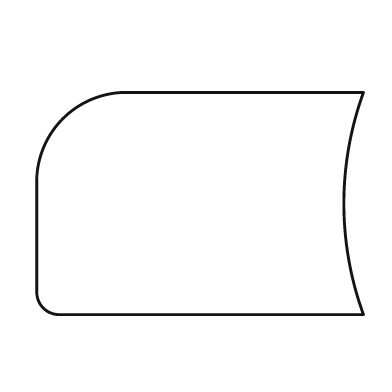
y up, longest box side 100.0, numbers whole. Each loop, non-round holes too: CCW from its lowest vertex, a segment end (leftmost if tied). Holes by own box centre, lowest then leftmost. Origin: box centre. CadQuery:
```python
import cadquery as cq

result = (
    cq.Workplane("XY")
    .moveTo(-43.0, -34.0)
    .lineTo(50.0, -34.0)
    .threePointArc((44.0, 0.0), (50.0, 34.0))
    .lineTo(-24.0, 34.0)
    .threePointArc((-42.0, 26.0), (-50.0, 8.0))
    .lineTo(-50.0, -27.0)
    .threePointArc((-48.0, -32.0), (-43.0, -34.0))
    .close()
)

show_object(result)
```